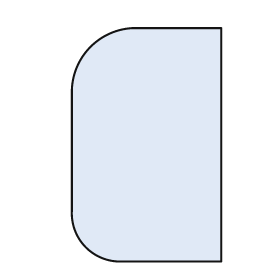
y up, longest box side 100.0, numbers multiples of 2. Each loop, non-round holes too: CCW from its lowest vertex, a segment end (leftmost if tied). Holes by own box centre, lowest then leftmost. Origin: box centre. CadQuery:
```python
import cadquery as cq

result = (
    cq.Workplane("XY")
    .moveTo(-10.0, -50.0)
    .lineTo(32.0, -50.0)
    .lineTo(32.0, 50.0)
    .lineTo(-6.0, 50.0)
    .threePointArc((-24.0, 42.0), (-32.0, 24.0))
    .lineTo(-32.0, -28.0)
    .threePointArc((-26.0, -44.0), (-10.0, -50.0))
    .close()
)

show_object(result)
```